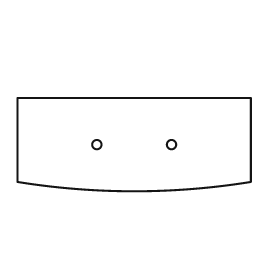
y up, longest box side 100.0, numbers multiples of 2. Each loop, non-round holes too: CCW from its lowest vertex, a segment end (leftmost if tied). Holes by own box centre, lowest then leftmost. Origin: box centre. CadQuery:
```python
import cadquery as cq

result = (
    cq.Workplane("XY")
    .moveTo(-50.0, -16.0)
    .threePointArc((0.0, -20.0), (50.0, -16.0))
    .lineTo(50.0, 20.0)
    .lineTo(-50.0, 20.0)
    .close()
    .moveTo(-16.0, 0.0)
    .circle(2.0)
    .moveTo(16.0, 0.0)
    .circle(2.0)
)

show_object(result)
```